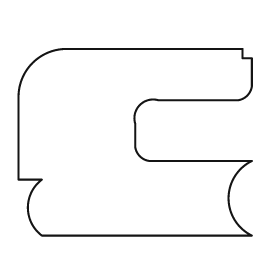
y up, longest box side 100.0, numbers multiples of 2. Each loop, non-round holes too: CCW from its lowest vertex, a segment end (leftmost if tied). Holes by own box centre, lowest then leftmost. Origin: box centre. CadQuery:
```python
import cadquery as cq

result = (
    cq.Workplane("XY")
    .moveTo(-40.0, -40.0)
    .lineTo(50.0, -40.0)
    .threePointArc((40.0, -24.0), (50.0, -8.0))
    .lineTo(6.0, -8.0)
    .threePointArc((2.0, -6.0), (0.0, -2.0))
    .lineTo(0.0, 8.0)
    .threePointArc((2.0, 16.0), (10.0, 18.0))
    .lineTo(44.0, 18.0)
    .threePointArc((48.0, 20.0), (50.0, 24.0))
    .lineTo(50.0, 36.0)
    .lineTo(46.0, 36.0)
    .lineTo(46.0, 40.0)
    .lineTo(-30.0, 40.0)
    .threePointArc((-44.0, 34.0), (-50.0, 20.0))
    .lineTo(-50.0, -16.0)
    .lineTo(-40.0, -16.0)
    .threePointArc((-46.0, -28.0), (-40.0, -40.0))
    .close()
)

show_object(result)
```